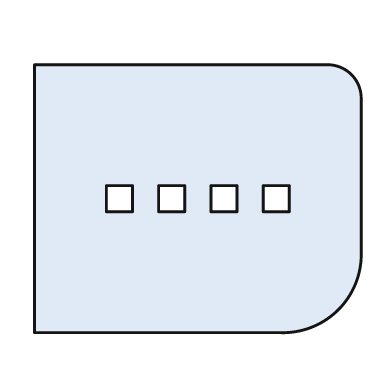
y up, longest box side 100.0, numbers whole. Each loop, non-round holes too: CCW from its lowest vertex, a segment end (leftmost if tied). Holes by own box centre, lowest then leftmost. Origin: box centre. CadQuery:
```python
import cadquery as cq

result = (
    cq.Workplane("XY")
    .moveTo(-50.0, -41.0)
    .lineTo(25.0, -41.0)
    .threePointArc((43.0, -34.0), (50.0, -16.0))
    .lineTo(50.0, 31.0)
    .threePointArc((47.0, 38.0), (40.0, 41.0))
    .lineTo(-50.0, 41.0)
    .close()
    .moveTo(-28.0, -4.0)
    .lineTo(-20.0, -4.0)
    .lineTo(-20.0, 4.0)
    .lineTo(-28.0, 4.0)
    .close()
    .moveTo(-12.0, -4.0)
    .lineTo(-4.0, -4.0)
    .lineTo(-4.0, 4.0)
    .lineTo(-12.0, 4.0)
    .close()
    .moveTo(4.0, -4.0)
    .lineTo(12.0, -4.0)
    .lineTo(12.0, 4.0)
    .lineTo(4.0, 4.0)
    .close()
    .moveTo(20.0, -4.0)
    .lineTo(28.0, -4.0)
    .lineTo(28.0, 4.0)
    .lineTo(20.0, 4.0)
    .close()
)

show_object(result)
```